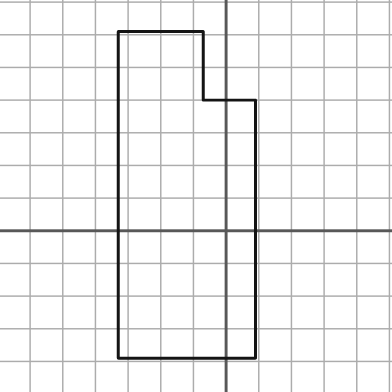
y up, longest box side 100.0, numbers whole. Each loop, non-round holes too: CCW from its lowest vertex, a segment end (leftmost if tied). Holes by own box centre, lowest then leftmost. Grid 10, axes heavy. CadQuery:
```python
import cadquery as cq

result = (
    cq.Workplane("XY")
    .moveTo(-33.0, -39.0)
    .lineTo(9.0, -39.0)
    .lineTo(9.0, 40.0)
    .lineTo(-7.0, 40.0)
    .lineTo(-7.0, 61.0)
    .lineTo(-33.0, 61.0)
    .close()
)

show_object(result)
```